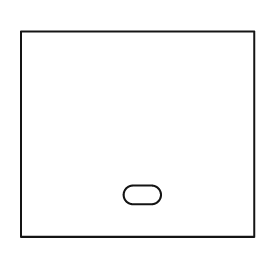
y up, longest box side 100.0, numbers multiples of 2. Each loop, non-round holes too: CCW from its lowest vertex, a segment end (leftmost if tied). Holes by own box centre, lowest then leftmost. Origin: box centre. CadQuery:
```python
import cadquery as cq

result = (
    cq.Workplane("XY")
    .moveTo(-50.0, -44.0)
    .lineTo(50.0, -44.0)
    .lineTo(50.0, 44.0)
    .lineTo(-50.0, 44.0)
    .close()
    .moveTo(-2.0, -30.0)
    .lineTo(6.0, -30.0)
    .threePointArc((10.0, -26.0), (6.0, -22.0))
    .lineTo(-2.0, -22.0)
    .threePointArc((-6.0, -26.0), (-2.0, -30.0))
    .close()
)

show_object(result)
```